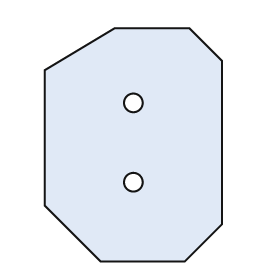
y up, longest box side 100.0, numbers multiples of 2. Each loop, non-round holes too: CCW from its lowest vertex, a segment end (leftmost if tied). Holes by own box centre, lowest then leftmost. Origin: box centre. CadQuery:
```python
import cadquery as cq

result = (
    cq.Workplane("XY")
    .moveTo(-14.0, -50.0)
    .lineTo(22.0, -50.0)
    .lineTo(38.0, -34.0)
    .lineTo(38.0, 36.0)
    .lineTo(24.0, 50.0)
    .lineTo(-8.0, 50.0)
    .lineTo(-38.0, 32.0)
    .lineTo(-38.0, -26.0)
    .close()
    .moveTo(0.0, -16.0)
    .circle(4.0)
    .moveTo(0.0, 18.0)
    .circle(4.0)
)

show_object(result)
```